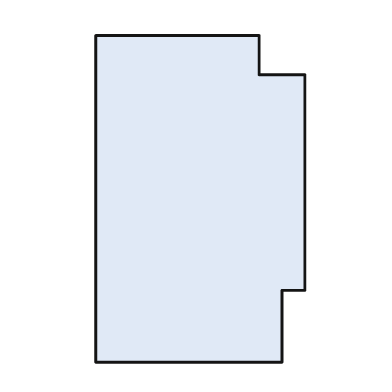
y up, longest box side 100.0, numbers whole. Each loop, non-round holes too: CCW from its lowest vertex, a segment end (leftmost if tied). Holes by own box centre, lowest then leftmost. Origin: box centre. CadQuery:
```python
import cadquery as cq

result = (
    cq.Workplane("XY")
    .moveTo(-32.0, -50.0)
    .lineTo(25.0, -50.0)
    .lineTo(25.0, -28.0)
    .lineTo(32.0, -28.0)
    .lineTo(32.0, 38.0)
    .lineTo(18.0, 38.0)
    .lineTo(18.0, 50.0)
    .lineTo(-32.0, 50.0)
    .close()
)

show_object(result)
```